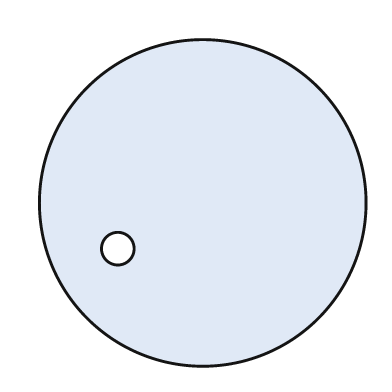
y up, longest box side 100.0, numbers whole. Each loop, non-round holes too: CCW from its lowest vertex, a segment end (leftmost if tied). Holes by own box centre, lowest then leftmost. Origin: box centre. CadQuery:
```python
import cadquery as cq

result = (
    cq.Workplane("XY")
    .moveTo(0.0, 0.0)
    .circle(50.0)
    .moveTo(-26.0, -14.0)
    .circle(5.0)
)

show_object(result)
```